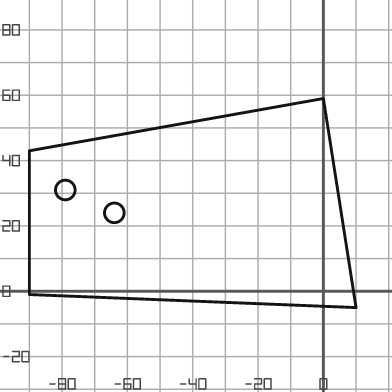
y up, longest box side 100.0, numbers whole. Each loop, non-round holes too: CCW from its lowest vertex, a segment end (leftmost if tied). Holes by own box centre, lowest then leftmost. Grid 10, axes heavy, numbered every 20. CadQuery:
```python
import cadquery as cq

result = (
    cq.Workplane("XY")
    .moveTo(10.0, -5.0)
    .lineTo(0.0, 59.0)
    .lineTo(-90.0, 43.0)
    .lineTo(-90.0, -1.0)
    .close()
    .moveTo(-64.0, 24.0)
    .circle(3.0)
    .moveTo(-79.0, 31.0)
    .circle(3.0)
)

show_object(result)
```